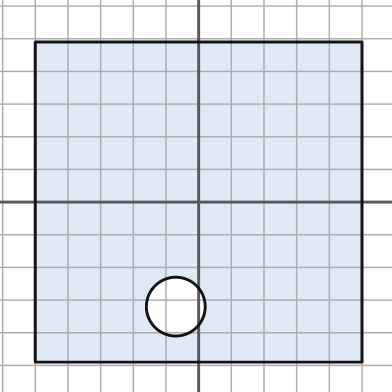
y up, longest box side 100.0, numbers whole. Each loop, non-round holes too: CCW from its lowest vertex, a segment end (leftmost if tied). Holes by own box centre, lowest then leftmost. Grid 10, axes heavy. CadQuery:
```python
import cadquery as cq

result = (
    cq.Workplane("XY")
    .moveTo(-50.0, -49.0)
    .lineTo(50.0, -49.0)
    .lineTo(50.0, 49.0)
    .lineTo(-50.0, 49.0)
    .close()
    .moveTo(-7.0, -32.0)
    .circle(9.0)
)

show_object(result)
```